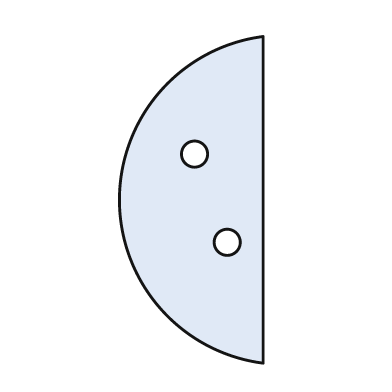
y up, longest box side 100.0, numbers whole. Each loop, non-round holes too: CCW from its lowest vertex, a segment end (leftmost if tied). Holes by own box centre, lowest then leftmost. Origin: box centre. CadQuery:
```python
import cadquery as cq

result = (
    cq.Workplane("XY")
    .moveTo(22.0, -50.0)
    .lineTo(22.0, 50.0)
    .threePointArc((-22.0, 0.0), (22.0, -50.0))
    .close()
    .moveTo(11.0, -13.0)
    .circle(4.0)
    .moveTo(1.0, 14.0)
    .circle(4.0)
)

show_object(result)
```